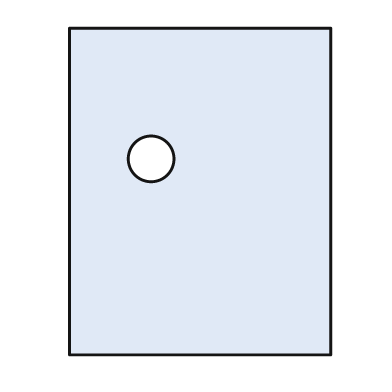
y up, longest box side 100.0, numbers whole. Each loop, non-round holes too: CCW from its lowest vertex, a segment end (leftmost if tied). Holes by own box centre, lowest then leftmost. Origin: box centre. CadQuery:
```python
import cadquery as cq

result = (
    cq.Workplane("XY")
    .moveTo(-40.0, -50.0)
    .lineTo(40.0, -50.0)
    .lineTo(40.0, 50.0)
    .lineTo(-40.0, 50.0)
    .close()
    .moveTo(-15.0, 10.0)
    .circle(7.0)
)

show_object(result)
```